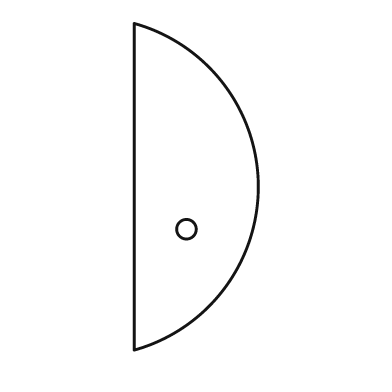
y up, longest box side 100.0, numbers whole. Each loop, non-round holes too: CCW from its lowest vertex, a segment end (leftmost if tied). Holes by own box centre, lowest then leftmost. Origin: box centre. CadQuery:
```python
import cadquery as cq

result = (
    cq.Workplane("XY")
    .moveTo(-19.0, -50.0)
    .threePointArc((19.0, 0.0), (-19.0, 50.0))
    .close()
    .moveTo(-3.0, -13.0)
    .circle(3.0)
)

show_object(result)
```